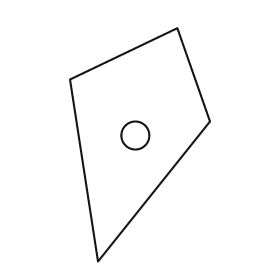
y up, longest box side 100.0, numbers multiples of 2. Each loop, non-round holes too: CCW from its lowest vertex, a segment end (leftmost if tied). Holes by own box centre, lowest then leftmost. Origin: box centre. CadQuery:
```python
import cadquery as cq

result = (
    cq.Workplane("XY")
    .moveTo(-18.0, -50.0)
    .lineTo(30.0, 10.0)
    .lineTo(16.0, 50.0)
    .lineTo(-30.0, 28.0)
    .close()
    .moveTo(-2.0, 4.0)
    .circle(6.0)
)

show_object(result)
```